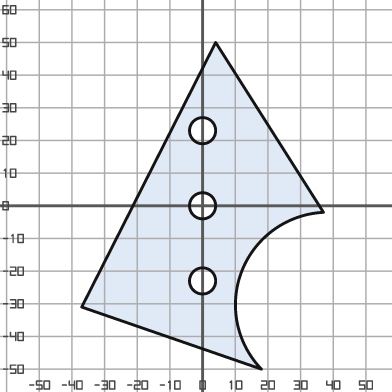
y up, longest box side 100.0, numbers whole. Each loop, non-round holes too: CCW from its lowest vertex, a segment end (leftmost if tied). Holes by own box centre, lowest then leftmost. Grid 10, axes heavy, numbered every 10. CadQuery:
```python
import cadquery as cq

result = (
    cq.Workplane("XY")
    .moveTo(18.0, -50.0)
    .threePointArc((12.0, -20.0), (37.0, -2.0))
    .lineTo(4.0, 50.0)
    .lineTo(-37.0, -31.0)
    .close()
    .moveTo(0.0, -23.0)
    .circle(4.0)
    .moveTo(0.0, 0.0)
    .circle(4.0)
    .moveTo(0.0, 23.0)
    .circle(4.0)
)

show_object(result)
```